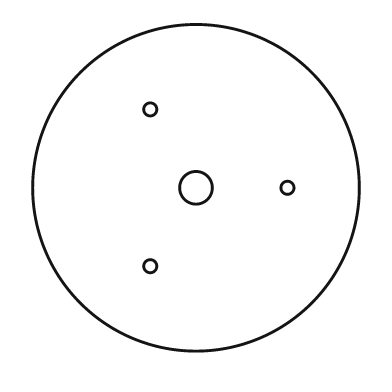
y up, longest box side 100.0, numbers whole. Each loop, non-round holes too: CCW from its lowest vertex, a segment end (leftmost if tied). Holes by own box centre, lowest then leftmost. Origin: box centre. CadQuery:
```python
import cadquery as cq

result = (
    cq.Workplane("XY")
    .moveTo(0.0, 0.0)
    .circle(50.0)
    .moveTo(-14.0, -24.0)
    .circle(2.0)
    .moveTo(0.0, 0.0)
    .circle(5.0)
    .moveTo(28.0, 0.0)
    .circle(2.0)
    .moveTo(-14.0, 24.0)
    .circle(2.0)
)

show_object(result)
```